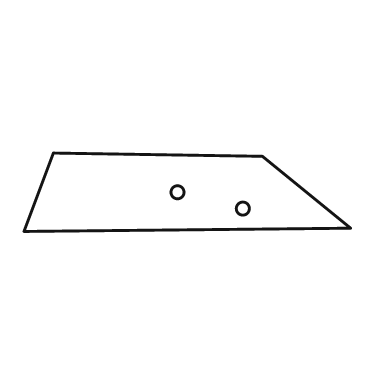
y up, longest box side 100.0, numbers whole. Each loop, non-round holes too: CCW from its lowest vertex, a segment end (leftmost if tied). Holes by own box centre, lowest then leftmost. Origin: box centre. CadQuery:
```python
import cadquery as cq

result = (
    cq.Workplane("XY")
    .moveTo(-50.0, -12.0)
    .lineTo(50.0, -11.0)
    .lineTo(23.0, 11.0)
    .lineTo(-41.0, 12.0)
    .close()
    .moveTo(17.0, -5.0)
    .circle(2.0)
    .moveTo(-3.0, 0.0)
    .circle(2.0)
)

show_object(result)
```